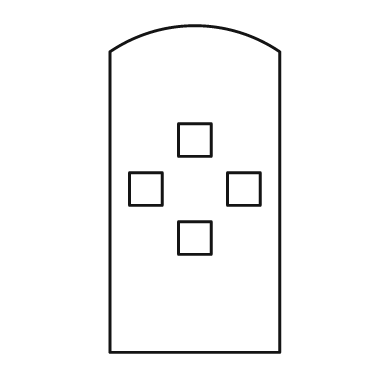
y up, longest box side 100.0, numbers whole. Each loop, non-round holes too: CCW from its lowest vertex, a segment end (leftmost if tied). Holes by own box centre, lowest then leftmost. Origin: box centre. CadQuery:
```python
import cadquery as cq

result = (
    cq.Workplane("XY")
    .moveTo(-26.0, -50.0)
    .lineTo(26.0, -50.0)
    .lineTo(26.0, 42.0)
    .threePointArc((0.0, 50.0), (-26.0, 42.0))
    .close()
    .moveTo(-5.0, -20.0)
    .lineTo(5.0, -20.0)
    .lineTo(5.0, -10.0)
    .lineTo(-5.0, -10.0)
    .close()
    .moveTo(-20.0, -5.0)
    .lineTo(-10.0, -5.0)
    .lineTo(-10.0, 5.0)
    .lineTo(-20.0, 5.0)
    .close()
    .moveTo(10.0, -5.0)
    .lineTo(20.0, -5.0)
    .lineTo(20.0, 5.0)
    .lineTo(10.0, 5.0)
    .close()
    .moveTo(-5.0, 10.0)
    .lineTo(5.0, 10.0)
    .lineTo(5.0, 20.0)
    .lineTo(-5.0, 20.0)
    .close()
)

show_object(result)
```